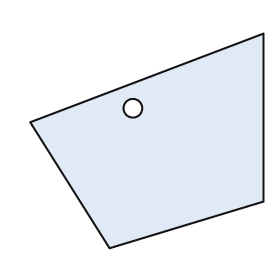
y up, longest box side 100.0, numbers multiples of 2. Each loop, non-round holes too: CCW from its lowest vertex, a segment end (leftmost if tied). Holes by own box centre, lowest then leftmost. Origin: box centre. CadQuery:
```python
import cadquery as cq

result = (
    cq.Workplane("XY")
    .moveTo(-16.0, -46.0)
    .lineTo(50.0, -26.0)
    .lineTo(50.0, 46.0)
    .lineTo(-50.0, 8.0)
    .close()
    .moveTo(-6.0, 14.0)
    .circle(4.0)
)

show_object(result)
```